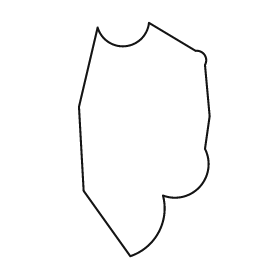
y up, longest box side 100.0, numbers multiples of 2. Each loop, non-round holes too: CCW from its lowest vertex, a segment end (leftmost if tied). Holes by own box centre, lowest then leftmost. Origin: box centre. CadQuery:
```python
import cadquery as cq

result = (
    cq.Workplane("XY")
    .moveTo(-6.0, -50.0)
    .threePointArc((6.0, -40.0), (8.0, -24.0))
    .threePointArc((24.0, -20.0), (26.0, -4.0))
    .lineTo(28.0, 10.0)
    .lineTo(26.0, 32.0)
    .threePointArc((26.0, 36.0), (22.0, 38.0))
    .lineTo(2.0, 50.0)
    .threePointArc((-8.0, 40.0), (-20.0, 48.0))
    .lineTo(-28.0, 14.0)
    .lineTo(-26.0, -22.0)
    .close()
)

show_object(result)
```